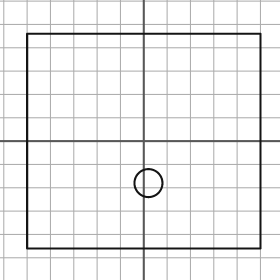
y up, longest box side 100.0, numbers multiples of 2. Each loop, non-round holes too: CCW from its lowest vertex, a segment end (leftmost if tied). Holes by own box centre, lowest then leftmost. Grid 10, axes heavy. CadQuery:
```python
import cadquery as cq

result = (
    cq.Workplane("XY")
    .moveTo(-50.0, -46.0)
    .lineTo(50.0, -46.0)
    .lineTo(50.0, 46.0)
    .lineTo(-50.0, 46.0)
    .close()
    .moveTo(2.0, -18.0)
    .circle(6.0)
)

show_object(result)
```